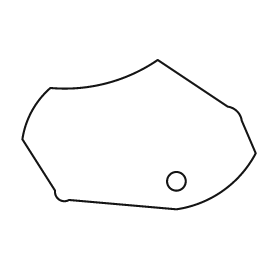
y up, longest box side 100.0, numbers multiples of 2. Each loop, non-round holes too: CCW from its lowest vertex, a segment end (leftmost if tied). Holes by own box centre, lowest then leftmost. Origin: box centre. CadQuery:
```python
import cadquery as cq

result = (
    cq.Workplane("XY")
    .moveTo(16.0, -32.0)
    .threePointArc((36.0, -24.0), (50.0, -8.0))
    .lineTo(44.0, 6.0)
    .threePointArc((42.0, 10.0), (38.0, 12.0))
    .lineTo(8.0, 32.0)
    .threePointArc((-14.0, 22.0), (-38.0, 20.0))
    .threePointArc((-46.0, 10.0), (-50.0, -2.0))
    .lineTo(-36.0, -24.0)
    .threePointArc((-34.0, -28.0), (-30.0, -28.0))
    .close()
    .moveTo(16.0, -20.0)
    .circle(4.0)
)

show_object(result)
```